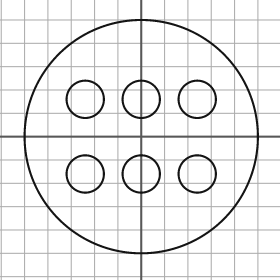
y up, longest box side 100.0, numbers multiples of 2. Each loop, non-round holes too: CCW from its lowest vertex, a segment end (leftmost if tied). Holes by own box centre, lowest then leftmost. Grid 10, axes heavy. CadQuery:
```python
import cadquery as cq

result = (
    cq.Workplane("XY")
    .moveTo(0.0, 0.0)
    .circle(50.0)
    .moveTo(-24.0, -16.0)
    .circle(8.0)
    .moveTo(0.0, -16.0)
    .circle(8.0)
    .moveTo(24.0, -16.0)
    .circle(8.0)
    .moveTo(-24.0, 16.0)
    .circle(8.0)
    .moveTo(0.0, 16.0)
    .circle(8.0)
    .moveTo(24.0, 16.0)
    .circle(8.0)
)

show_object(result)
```